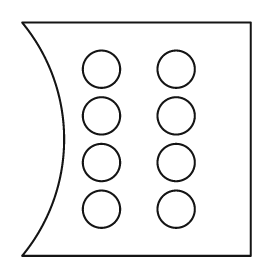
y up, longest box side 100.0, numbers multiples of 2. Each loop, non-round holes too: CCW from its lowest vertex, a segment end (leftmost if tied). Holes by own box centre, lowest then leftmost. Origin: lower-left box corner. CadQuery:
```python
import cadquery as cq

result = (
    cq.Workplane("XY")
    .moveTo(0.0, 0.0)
    .lineTo(98.0, 0.0)
    .lineTo(98.0, 100.0)
    .lineTo(0.0, 100.0)
    .threePointArc((18.0, 50.0), (0.0, 0.0))
    .close()
    .moveTo(34.0, 20.0)
    .circle(8.0)
    .moveTo(66.0, 20.0)
    .circle(8.0)
    .moveTo(34.0, 40.0)
    .circle(8.0)
    .moveTo(66.0, 40.0)
    .circle(8.0)
    .moveTo(34.0, 60.0)
    .circle(8.0)
    .moveTo(66.0, 60.0)
    .circle(8.0)
    .moveTo(34.0, 80.0)
    .circle(8.0)
    .moveTo(66.0, 80.0)
    .circle(8.0)
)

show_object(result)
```